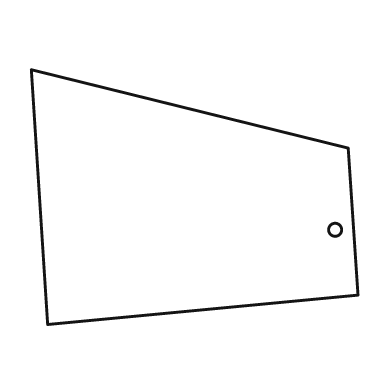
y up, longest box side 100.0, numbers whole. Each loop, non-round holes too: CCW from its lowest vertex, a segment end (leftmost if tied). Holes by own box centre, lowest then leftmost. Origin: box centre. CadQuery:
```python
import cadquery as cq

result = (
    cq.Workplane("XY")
    .moveTo(-45.0, -39.0)
    .lineTo(50.0, -30.0)
    .lineTo(47.0, 15.0)
    .lineTo(-50.0, 39.0)
    .close()
    .moveTo(43.0, -10.0)
    .circle(2.0)
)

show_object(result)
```